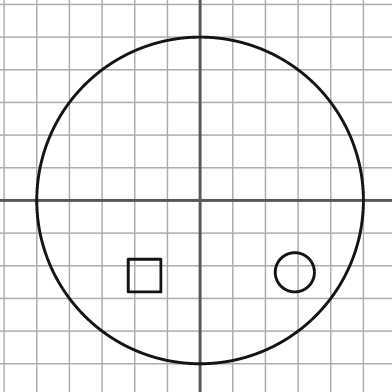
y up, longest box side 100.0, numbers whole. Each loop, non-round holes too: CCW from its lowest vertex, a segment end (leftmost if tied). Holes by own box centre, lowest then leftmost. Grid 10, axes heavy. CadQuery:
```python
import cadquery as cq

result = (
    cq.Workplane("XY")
    .moveTo(0.0, 0.0)
    .circle(50.0)
    .moveTo(-22.0, -28.0)
    .lineTo(-12.0, -28.0)
    .lineTo(-12.0, -18.0)
    .lineTo(-22.0, -18.0)
    .close()
    .moveTo(29.0, -22.0)
    .circle(6.0)
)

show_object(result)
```